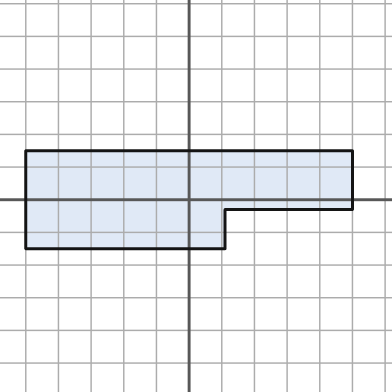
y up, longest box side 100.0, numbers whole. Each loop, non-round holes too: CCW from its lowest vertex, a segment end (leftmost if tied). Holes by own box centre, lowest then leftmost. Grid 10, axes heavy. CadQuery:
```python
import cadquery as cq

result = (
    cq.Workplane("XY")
    .moveTo(-50.0, -15.0)
    .lineTo(11.0, -15.0)
    .lineTo(11.0, -3.0)
    .lineTo(50.0, -3.0)
    .lineTo(50.0, 15.0)
    .lineTo(-50.0, 15.0)
    .close()
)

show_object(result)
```